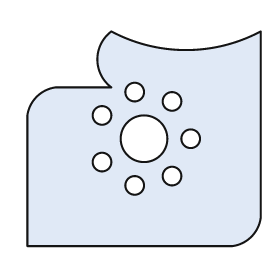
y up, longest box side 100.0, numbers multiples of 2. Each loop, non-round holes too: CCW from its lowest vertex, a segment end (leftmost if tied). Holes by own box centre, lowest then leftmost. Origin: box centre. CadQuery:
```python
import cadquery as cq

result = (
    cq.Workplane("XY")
    .moveTo(-50.0, -46.0)
    .lineTo(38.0, -46.0)
    .threePointArc((46.0, -42.0), (50.0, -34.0))
    .lineTo(50.0, 46.0)
    .threePointArc((18.0, 38.0), (-14.0, 46.0))
    .threePointArc((-20.0, 34.0), (-14.0, 22.0))
    .lineTo(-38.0, 22.0)
    .threePointArc((-46.0, 18.0), (-50.0, 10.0))
    .close()
    .moveTo(-4.0, -20.0)
    .circle(4.0)
    .moveTo(12.0, -16.0)
    .circle(4.0)
    .moveTo(-18.0, -10.0)
    .circle(4.0)
    .moveTo(0.0, 0.0)
    .circle(10.0)
    .moveTo(20.0, 0.0)
    .circle(4.0)
    .moveTo(-18.0, 10.0)
    .circle(4.0)
    .moveTo(12.0, 16.0)
    .circle(4.0)
    .moveTo(-4.0, 20.0)
    .circle(4.0)
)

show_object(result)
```